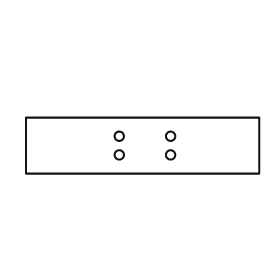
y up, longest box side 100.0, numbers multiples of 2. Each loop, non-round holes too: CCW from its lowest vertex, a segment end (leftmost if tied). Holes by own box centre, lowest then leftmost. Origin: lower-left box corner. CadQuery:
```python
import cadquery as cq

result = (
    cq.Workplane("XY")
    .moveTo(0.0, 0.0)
    .lineTo(100.0, 0.0)
    .lineTo(100.0, 24.0)
    .lineTo(0.0, 24.0)
    .close()
    .moveTo(40.0, 8.0)
    .circle(2.0)
    .moveTo(62.0, 8.0)
    .circle(2.0)
    .moveTo(40.0, 16.0)
    .circle(2.0)
    .moveTo(62.0, 16.0)
    .circle(2.0)
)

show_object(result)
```